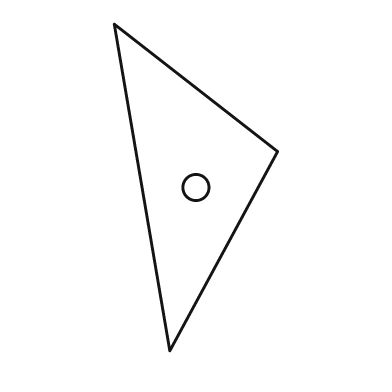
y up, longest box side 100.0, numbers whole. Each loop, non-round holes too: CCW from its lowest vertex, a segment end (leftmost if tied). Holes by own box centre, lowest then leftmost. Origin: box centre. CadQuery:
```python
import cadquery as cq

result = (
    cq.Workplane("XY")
    .moveTo(-8.0, -50.0)
    .lineTo(25.0, 11.0)
    .lineTo(-25.0, 50.0)
    .close()
    .moveTo(0.0, 0.0)
    .circle(4.0)
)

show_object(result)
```